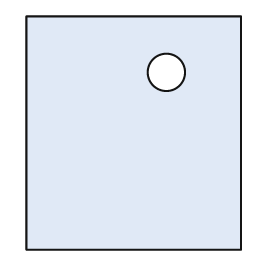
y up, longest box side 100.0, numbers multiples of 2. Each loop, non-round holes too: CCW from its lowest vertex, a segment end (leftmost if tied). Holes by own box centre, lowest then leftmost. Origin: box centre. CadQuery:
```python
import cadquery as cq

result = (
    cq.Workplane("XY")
    .moveTo(-46.0, -50.0)
    .lineTo(46.0, -50.0)
    .lineTo(46.0, 50.0)
    .lineTo(-46.0, 50.0)
    .close()
    .moveTo(14.0, 26.0)
    .circle(8.0)
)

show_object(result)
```